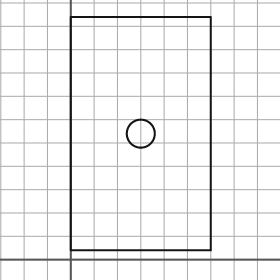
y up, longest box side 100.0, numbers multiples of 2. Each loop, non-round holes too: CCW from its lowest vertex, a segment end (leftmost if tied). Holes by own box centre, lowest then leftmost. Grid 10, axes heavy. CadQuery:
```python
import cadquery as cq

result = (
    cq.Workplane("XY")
    .moveTo(0.0, 4.0)
    .lineTo(60.0, 4.0)
    .lineTo(60.0, 104.0)
    .lineTo(0.0, 104.0)
    .close()
    .moveTo(30.0, 54.0)
    .circle(6.0)
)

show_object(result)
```